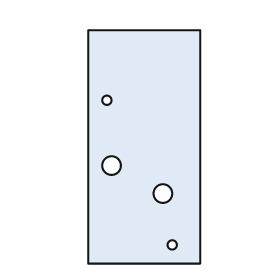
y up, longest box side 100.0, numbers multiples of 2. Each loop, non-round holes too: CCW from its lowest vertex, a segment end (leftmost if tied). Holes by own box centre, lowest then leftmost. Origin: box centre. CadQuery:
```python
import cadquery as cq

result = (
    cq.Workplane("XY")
    .moveTo(-24.0, -50.0)
    .lineTo(24.0, -50.0)
    .lineTo(24.0, 50.0)
    .lineTo(-24.0, 50.0)
    .close()
    .moveTo(12.0, -42.0)
    .circle(2.0)
    .moveTo(8.0, -20.0)
    .circle(4.0)
    .moveTo(-14.0, -8.0)
    .circle(4.0)
    .moveTo(-16.0, 20.0)
    .circle(2.0)
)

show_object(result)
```